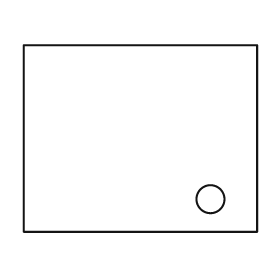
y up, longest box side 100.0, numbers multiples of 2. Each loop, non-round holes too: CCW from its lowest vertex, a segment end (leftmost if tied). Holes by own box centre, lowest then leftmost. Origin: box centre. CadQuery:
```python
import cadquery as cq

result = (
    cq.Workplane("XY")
    .moveTo(-50.0, -40.0)
    .lineTo(50.0, -40.0)
    .lineTo(50.0, 40.0)
    .lineTo(-50.0, 40.0)
    .close()
    .moveTo(30.0, -26.0)
    .circle(6.0)
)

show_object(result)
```